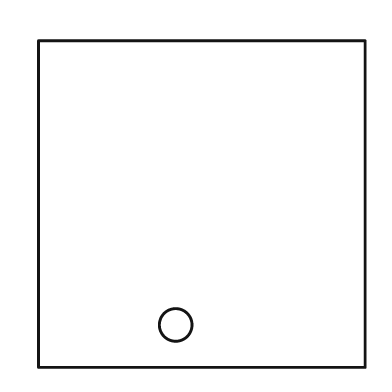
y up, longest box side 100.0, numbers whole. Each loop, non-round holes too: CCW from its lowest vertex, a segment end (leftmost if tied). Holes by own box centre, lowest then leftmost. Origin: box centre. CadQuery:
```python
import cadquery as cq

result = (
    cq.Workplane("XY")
    .moveTo(-50.0, -50.0)
    .lineTo(50.0, -50.0)
    .lineTo(50.0, 50.0)
    .lineTo(-50.0, 50.0)
    .close()
    .moveTo(-8.0, -37.0)
    .circle(5.0)
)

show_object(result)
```